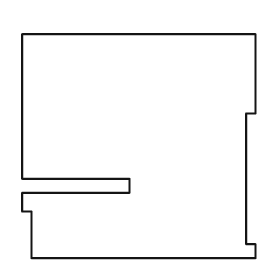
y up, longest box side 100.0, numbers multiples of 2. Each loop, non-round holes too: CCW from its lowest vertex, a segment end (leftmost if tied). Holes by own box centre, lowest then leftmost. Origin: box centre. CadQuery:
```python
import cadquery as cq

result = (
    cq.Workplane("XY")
    .moveTo(-46.0, -48.0)
    .lineTo(50.0, -48.0)
    .lineTo(50.0, -42.0)
    .lineTo(46.0, -42.0)
    .lineTo(46.0, 14.0)
    .lineTo(50.0, 14.0)
    .lineTo(50.0, 48.0)
    .lineTo(-50.0, 48.0)
    .lineTo(-50.0, -14.0)
    .lineTo(-4.0, -14.0)
    .lineTo(-4.0, -20.0)
    .lineTo(-50.0, -20.0)
    .lineTo(-50.0, -28.0)
    .lineTo(-46.0, -28.0)
    .close()
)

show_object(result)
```